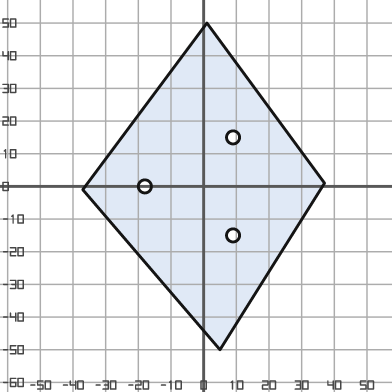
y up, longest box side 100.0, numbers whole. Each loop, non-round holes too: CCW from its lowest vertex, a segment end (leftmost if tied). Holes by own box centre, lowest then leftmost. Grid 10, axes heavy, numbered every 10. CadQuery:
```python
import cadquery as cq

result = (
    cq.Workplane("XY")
    .moveTo(5.0, -50.0)
    .lineTo(37.0, 1.0)
    .lineTo(1.0, 50.0)
    .lineTo(-37.0, -1.0)
    .close()
    .moveTo(9.0, -15.0)
    .circle(2.0)
    .moveTo(-18.0, 0.0)
    .circle(2.0)
    .moveTo(9.0, 15.0)
    .circle(2.0)
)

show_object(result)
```